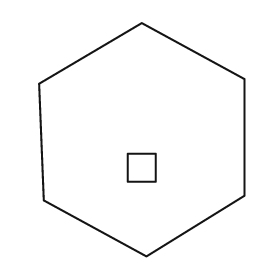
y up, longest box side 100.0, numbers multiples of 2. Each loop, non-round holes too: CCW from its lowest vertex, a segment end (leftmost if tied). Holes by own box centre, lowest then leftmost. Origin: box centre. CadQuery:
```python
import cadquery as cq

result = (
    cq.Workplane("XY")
    .moveTo(2.0, -50.0)
    .lineTo(44.0, -24.0)
    .lineTo(44.0, 26.0)
    .lineTo(0.0, 50.0)
    .lineTo(-44.0, 24.0)
    .lineTo(-42.0, -26.0)
    .close()
    .moveTo(-6.0, -18.0)
    .lineTo(6.0, -18.0)
    .lineTo(6.0, -6.0)
    .lineTo(-6.0, -6.0)
    .close()
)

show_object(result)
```